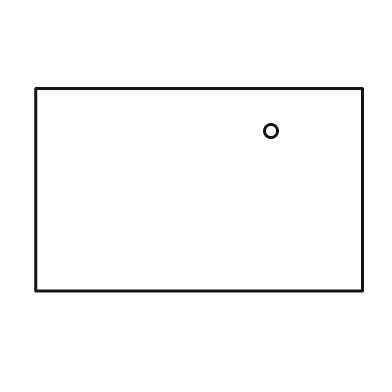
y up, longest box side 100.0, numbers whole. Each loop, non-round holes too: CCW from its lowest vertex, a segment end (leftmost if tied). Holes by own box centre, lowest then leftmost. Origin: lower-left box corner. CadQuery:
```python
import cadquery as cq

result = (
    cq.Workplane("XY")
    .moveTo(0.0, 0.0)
    .lineTo(100.0, 0.0)
    .lineTo(100.0, 62.0)
    .lineTo(0.0, 62.0)
    .close()
    .moveTo(72.0, 49.0)
    .circle(2.0)
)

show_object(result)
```